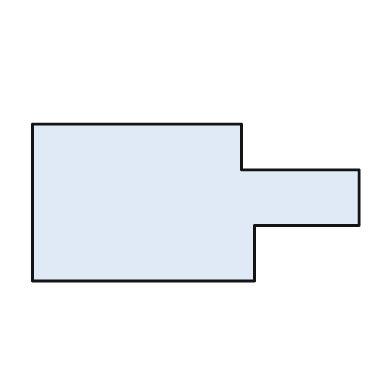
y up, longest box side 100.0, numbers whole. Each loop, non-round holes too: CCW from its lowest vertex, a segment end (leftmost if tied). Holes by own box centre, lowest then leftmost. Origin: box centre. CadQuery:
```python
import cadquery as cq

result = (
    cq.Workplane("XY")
    .moveTo(-50.0, -24.0)
    .lineTo(18.0, -24.0)
    .lineTo(18.0, -7.0)
    .lineTo(50.0, -7.0)
    .lineTo(50.0, 10.0)
    .lineTo(14.0, 10.0)
    .lineTo(14.0, 24.0)
    .lineTo(-50.0, 24.0)
    .close()
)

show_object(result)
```